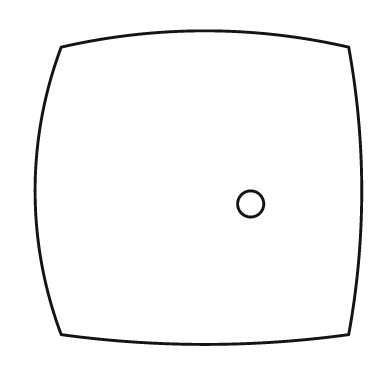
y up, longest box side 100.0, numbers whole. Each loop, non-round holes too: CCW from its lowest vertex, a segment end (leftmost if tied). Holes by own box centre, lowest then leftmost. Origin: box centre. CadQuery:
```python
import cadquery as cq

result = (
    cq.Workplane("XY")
    .moveTo(-42.0, -45.0)
    .threePointArc((2.0, -48.0), (46.0, -45.0))
    .threePointArc((50.0, -1.0), (46.0, 43.0))
    .threePointArc((2.0, 48.0), (-42.0, 43.0))
    .threePointArc((-50.0, -1.0), (-42.0, -45.0))
    .close()
    .moveTo(16.0, -5.0)
    .circle(4.0)
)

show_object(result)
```